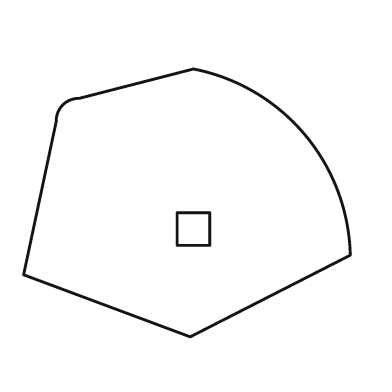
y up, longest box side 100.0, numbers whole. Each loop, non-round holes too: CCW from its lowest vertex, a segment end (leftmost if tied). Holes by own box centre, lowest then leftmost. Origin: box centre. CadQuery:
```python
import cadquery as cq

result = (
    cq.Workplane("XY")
    .moveTo(1.0, -41.0)
    .lineTo(50.0, -16.0)
    .threePointArc((36.0, 21.0), (2.0, 41.0))
    .lineTo(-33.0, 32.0)
    .threePointArc((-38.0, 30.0), (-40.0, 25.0))
    .lineTo(-50.0, -22.0)
    .close()
    .moveTo(-3.0, -13.0)
    .lineTo(7.0, -13.0)
    .lineTo(7.0, -3.0)
    .lineTo(-3.0, -3.0)
    .close()
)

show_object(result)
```